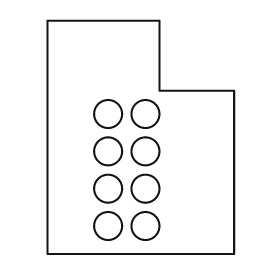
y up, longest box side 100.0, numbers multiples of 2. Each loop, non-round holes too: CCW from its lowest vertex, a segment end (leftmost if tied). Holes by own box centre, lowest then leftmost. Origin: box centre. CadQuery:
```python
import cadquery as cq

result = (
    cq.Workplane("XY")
    .moveTo(-40.0, -50.0)
    .lineTo(40.0, -50.0)
    .lineTo(40.0, 20.0)
    .lineTo(8.0, 20.0)
    .lineTo(8.0, 50.0)
    .lineTo(-40.0, 50.0)
    .close()
    .moveTo(-14.0, -38.0)
    .circle(6.0)
    .moveTo(2.0, -38.0)
    .circle(6.0)
    .moveTo(-14.0, -22.0)
    .circle(6.0)
    .moveTo(2.0, -22.0)
    .circle(6.0)
    .moveTo(-14.0, -6.0)
    .circle(6.0)
    .moveTo(2.0, -6.0)
    .circle(6.0)
    .moveTo(-14.0, 10.0)
    .circle(6.0)
    .moveTo(2.0, 10.0)
    .circle(6.0)
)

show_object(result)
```